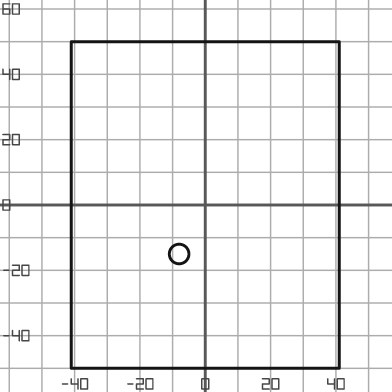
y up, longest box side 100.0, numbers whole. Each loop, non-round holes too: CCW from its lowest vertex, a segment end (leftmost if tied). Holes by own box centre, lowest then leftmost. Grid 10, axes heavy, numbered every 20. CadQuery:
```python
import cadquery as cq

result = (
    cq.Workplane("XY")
    .moveTo(-41.0, -50.0)
    .lineTo(41.0, -50.0)
    .lineTo(41.0, 50.0)
    .lineTo(-41.0, 50.0)
    .close()
    .moveTo(-8.0, -15.0)
    .circle(3.0)
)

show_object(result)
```